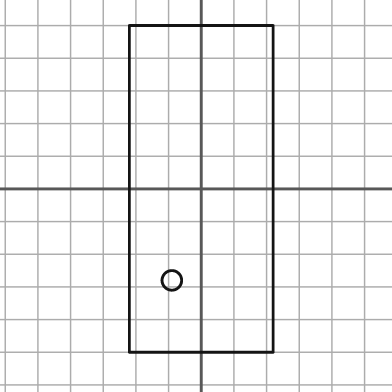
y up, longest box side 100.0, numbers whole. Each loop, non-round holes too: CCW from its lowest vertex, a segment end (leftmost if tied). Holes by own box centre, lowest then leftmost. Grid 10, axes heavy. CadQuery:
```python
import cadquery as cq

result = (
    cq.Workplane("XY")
    .moveTo(-22.0, -50.0)
    .lineTo(22.0, -50.0)
    .lineTo(22.0, 50.0)
    .lineTo(-22.0, 50.0)
    .close()
    .moveTo(-9.0, -28.0)
    .circle(3.0)
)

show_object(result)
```